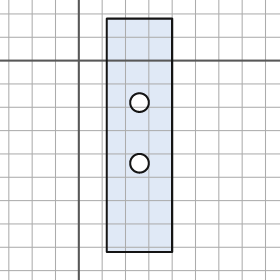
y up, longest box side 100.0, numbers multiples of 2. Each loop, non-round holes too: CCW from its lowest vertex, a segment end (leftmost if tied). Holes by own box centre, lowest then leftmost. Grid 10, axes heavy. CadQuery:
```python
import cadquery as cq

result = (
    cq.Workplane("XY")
    .moveTo(12.0, -82.0)
    .lineTo(40.0, -82.0)
    .lineTo(40.0, 18.0)
    .lineTo(12.0, 18.0)
    .close()
    .moveTo(26.0, -44.0)
    .circle(4.0)
    .moveTo(26.0, -18.0)
    .circle(4.0)
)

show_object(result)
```